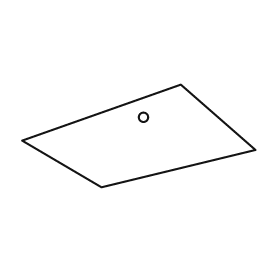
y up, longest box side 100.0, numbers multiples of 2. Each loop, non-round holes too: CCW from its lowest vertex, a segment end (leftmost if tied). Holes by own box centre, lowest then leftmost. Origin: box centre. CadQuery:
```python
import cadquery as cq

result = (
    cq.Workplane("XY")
    .moveTo(-16.0, -22.0)
    .lineTo(50.0, -6.0)
    .lineTo(18.0, 22.0)
    .lineTo(-50.0, -2.0)
    .close()
    .moveTo(2.0, 8.0)
    .circle(2.0)
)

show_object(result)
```